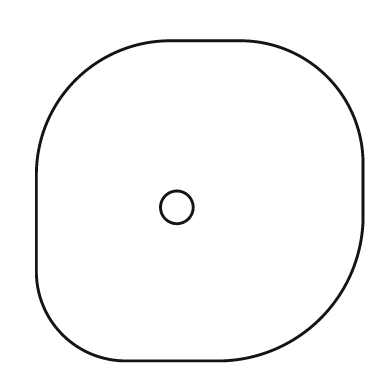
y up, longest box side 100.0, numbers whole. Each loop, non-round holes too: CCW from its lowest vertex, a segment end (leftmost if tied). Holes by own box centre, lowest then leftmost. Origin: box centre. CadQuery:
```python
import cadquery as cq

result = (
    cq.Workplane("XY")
    .moveTo(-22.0, -49.0)
    .lineTo(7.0, -49.0)
    .threePointArc((37.0, -36.0), (50.0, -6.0))
    .lineTo(50.0, 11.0)
    .threePointArc((39.0, 38.0), (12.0, 49.0))
    .lineTo(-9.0, 49.0)
    .threePointArc((-38.0, 37.0), (-50.0, 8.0))
    .lineTo(-50.0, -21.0)
    .threePointArc((-42.0, -41.0), (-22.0, -49.0))
    .close()
    .moveTo(-7.0, -2.0)
    .circle(5.0)
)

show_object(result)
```